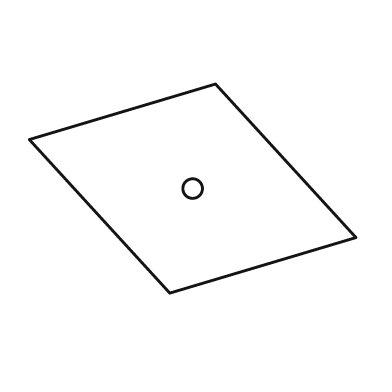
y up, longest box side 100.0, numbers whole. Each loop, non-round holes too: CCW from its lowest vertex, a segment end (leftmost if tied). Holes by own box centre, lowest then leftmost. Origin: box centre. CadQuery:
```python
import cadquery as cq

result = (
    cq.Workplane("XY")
    .moveTo(-7.0, -32.0)
    .lineTo(50.0, -15.0)
    .lineTo(7.0, 32.0)
    .lineTo(-50.0, 15.0)
    .close()
    .moveTo(0.0, 0.0)
    .circle(3.0)
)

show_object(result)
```